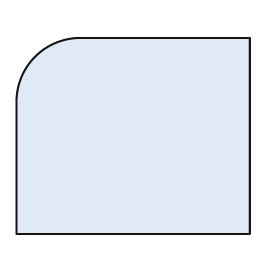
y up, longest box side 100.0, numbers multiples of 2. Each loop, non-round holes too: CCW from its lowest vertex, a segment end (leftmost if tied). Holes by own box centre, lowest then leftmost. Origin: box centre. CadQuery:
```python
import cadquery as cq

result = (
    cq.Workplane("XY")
    .moveTo(-50.0, -42.0)
    .lineTo(50.0, -42.0)
    .lineTo(50.0, 42.0)
    .lineTo(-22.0, 42.0)
    .threePointArc((-42.0, 34.0), (-50.0, 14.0))
    .close()
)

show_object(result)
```